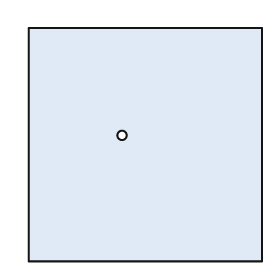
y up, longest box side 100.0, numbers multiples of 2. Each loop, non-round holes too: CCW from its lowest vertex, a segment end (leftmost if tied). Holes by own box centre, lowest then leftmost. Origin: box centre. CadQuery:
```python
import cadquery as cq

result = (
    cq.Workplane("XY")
    .moveTo(-50.0, -50.0)
    .lineTo(50.0, -50.0)
    .lineTo(50.0, 50.0)
    .lineTo(-50.0, 50.0)
    .close()
    .moveTo(-10.0, 4.0)
    .circle(2.0)
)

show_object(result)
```